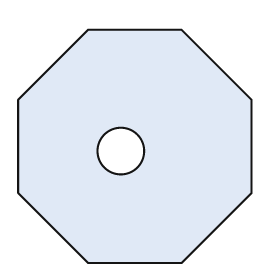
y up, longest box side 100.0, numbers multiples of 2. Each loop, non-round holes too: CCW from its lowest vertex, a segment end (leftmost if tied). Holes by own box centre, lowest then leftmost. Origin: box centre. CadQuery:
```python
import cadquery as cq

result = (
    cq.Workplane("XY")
    .moveTo(-20.0, -50.0)
    .lineTo(20.0, -50.0)
    .lineTo(50.0, -20.0)
    .lineTo(50.0, 20.0)
    .lineTo(20.0, 50.0)
    .lineTo(-20.0, 50.0)
    .lineTo(-50.0, 20.0)
    .lineTo(-50.0, -20.0)
    .close()
    .moveTo(-6.0, -2.0)
    .circle(10.0)
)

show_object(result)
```